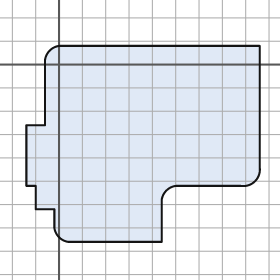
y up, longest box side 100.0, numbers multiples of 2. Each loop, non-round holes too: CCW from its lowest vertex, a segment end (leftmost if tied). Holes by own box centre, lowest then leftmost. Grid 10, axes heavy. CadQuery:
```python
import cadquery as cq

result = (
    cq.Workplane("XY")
    .moveTo(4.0, -76.0)
    .lineTo(44.0, -76.0)
    .lineTo(44.0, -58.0)
    .threePointArc((46.0, -54.0), (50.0, -52.0))
    .lineTo(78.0, -52.0)
    .threePointArc((84.0, -50.0), (86.0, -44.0))
    .lineTo(86.0, 8.0)
    .lineTo(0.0, 8.0)
    .threePointArc((-4.0, 6.0), (-6.0, 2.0))
    .lineTo(-6.0, -26.0)
    .lineTo(-14.0, -26.0)
    .lineTo(-14.0, -52.0)
    .lineTo(-10.0, -52.0)
    .lineTo(-10.0, -62.0)
    .lineTo(-2.0, -62.0)
    .lineTo(-2.0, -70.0)
    .threePointArc((0.0, -74.0), (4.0, -76.0))
    .close()
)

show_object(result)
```